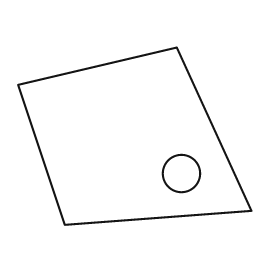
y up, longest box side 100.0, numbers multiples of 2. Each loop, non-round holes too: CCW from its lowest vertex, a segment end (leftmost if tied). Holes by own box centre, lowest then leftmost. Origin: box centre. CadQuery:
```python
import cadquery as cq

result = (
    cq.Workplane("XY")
    .moveTo(-30.0, -38.0)
    .lineTo(50.0, -32.0)
    .lineTo(18.0, 38.0)
    .lineTo(-50.0, 22.0)
    .close()
    .moveTo(20.0, -16.0)
    .circle(8.0)
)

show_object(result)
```